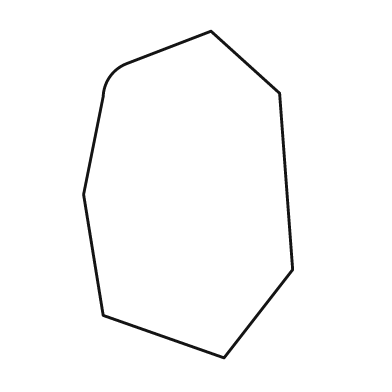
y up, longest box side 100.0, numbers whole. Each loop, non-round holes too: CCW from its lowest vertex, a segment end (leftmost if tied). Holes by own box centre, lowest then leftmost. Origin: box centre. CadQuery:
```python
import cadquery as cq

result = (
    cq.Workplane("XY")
    .moveTo(11.0, -50.0)
    .lineTo(32.0, -23.0)
    .lineTo(28.0, 31.0)
    .lineTo(7.0, 50.0)
    .lineTo(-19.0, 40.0)
    .threePointArc((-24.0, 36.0), (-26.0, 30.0))
    .lineTo(-32.0, 0.0)
    .lineTo(-26.0, -37.0)
    .close()
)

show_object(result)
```